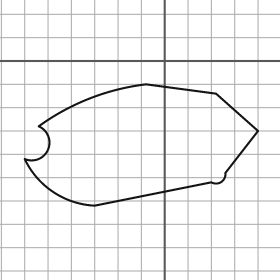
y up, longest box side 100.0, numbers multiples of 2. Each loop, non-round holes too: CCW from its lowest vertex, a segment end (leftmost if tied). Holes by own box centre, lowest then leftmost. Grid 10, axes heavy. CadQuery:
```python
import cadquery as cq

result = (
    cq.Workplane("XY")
    .moveTo(-30.0, -62.0)
    .lineTo(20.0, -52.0)
    .threePointArc((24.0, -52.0), (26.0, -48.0))
    .lineTo(40.0, -30.0)
    .lineTo(22.0, -14.0)
    .lineTo(-8.0, -10.0)
    .threePointArc((-32.0, -16.0), (-54.0, -28.0))
    .threePointArc((-50.0, -38.0), (-60.0, -42.0))
    .threePointArc((-48.0, -56.0), (-30.0, -62.0))
    .close()
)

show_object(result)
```